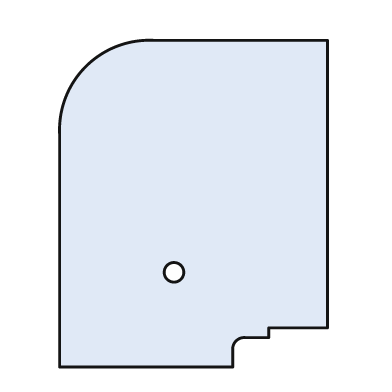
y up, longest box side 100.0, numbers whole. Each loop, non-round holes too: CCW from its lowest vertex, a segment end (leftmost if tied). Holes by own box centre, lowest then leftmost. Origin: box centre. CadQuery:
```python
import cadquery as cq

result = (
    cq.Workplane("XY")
    .moveTo(-41.0, -50.0)
    .lineTo(12.0, -50.0)
    .lineTo(12.0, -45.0)
    .threePointArc((13.0, -42.0), (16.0, -41.0))
    .lineTo(23.0, -41.0)
    .lineTo(23.0, -38.0)
    .lineTo(41.0, -38.0)
    .lineTo(41.0, 50.0)
    .lineTo(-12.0, 50.0)
    .threePointArc((-33.0, 42.0), (-41.0, 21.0))
    .close()
    .moveTo(-6.0, -21.0)
    .circle(3.0)
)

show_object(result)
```